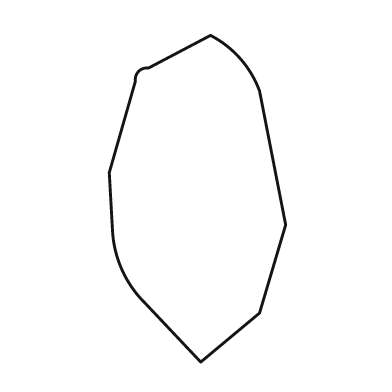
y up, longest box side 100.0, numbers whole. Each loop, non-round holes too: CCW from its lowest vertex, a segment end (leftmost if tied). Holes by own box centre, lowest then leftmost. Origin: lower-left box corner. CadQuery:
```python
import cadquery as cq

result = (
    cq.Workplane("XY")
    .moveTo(28.0, 0.0)
    .lineTo(46.0, 15.0)
    .lineTo(54.0, 42.0)
    .lineTo(46.0, 83.0)
    .threePointArc((40.0, 93.0), (31.0, 100.0))
    .lineTo(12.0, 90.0)
    .threePointArc((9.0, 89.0), (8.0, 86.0))
    .lineTo(0.0, 58.0)
    .lineTo(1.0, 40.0)
    .threePointArc((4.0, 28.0), (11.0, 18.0))
    .close()
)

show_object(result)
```